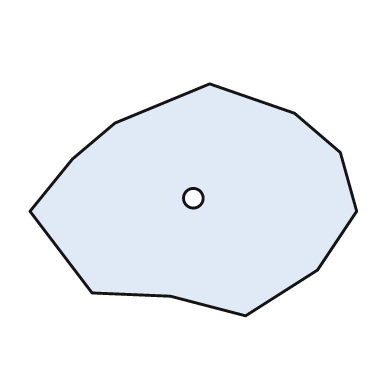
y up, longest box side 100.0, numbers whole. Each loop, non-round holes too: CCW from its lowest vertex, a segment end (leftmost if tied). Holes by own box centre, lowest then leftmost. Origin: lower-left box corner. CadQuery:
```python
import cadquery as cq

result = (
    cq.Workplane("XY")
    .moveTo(66.0, 0.0)
    .lineTo(88.0, 14.0)
    .lineTo(100.0, 32.0)
    .lineTo(95.0, 50.0)
    .lineTo(81.0, 62.0)
    .lineTo(55.0, 71.0)
    .lineTo(26.0, 59.0)
    .lineTo(13.0, 48.0)
    .lineTo(0.0, 32.0)
    .lineTo(19.0, 7.0)
    .lineTo(43.0, 6.0)
    .close()
    .moveTo(50.0, 36.0)
    .circle(3.0)
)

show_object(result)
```